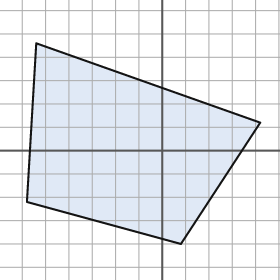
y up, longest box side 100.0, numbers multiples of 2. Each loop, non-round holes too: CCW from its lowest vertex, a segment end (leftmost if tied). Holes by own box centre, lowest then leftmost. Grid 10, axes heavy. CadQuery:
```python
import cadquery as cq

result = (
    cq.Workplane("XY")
    .moveTo(8.0, -40.0)
    .lineTo(42.0, 12.0)
    .lineTo(-54.0, 46.0)
    .lineTo(-58.0, -22.0)
    .close()
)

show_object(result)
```